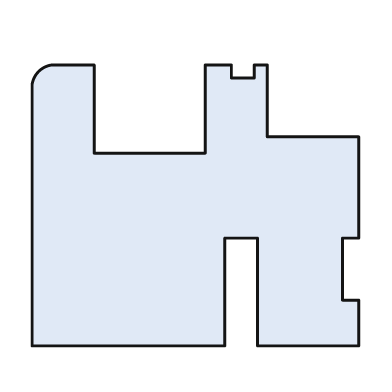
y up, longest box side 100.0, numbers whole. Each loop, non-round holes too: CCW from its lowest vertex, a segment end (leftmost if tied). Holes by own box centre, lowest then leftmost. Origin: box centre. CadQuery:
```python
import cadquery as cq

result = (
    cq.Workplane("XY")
    .moveTo(-50.0, -43.0)
    .lineTo(9.0, -43.0)
    .lineTo(9.0, -10.0)
    .lineTo(19.0, -10.0)
    .lineTo(19.0, -43.0)
    .lineTo(50.0, -43.0)
    .lineTo(50.0, -29.0)
    .lineTo(45.0, -29.0)
    .lineTo(45.0, -10.0)
    .lineTo(50.0, -10.0)
    .lineTo(50.0, 21.0)
    .lineTo(22.0, 21.0)
    .lineTo(22.0, 43.0)
    .lineTo(18.0, 43.0)
    .lineTo(18.0, 39.0)
    .lineTo(11.0, 39.0)
    .lineTo(11.0, 43.0)
    .lineTo(3.0, 43.0)
    .lineTo(3.0, 16.0)
    .lineTo(-31.0, 16.0)
    .lineTo(-31.0, 43.0)
    .lineTo(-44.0, 43.0)
    .threePointArc((-48.0, 41.0), (-50.0, 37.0))
    .close()
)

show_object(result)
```